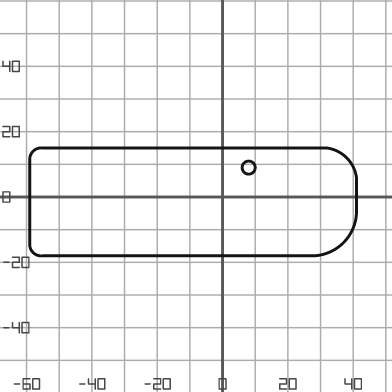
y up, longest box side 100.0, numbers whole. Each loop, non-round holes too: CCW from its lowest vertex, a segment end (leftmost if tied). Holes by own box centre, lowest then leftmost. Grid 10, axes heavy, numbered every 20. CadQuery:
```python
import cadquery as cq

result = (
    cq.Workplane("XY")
    .moveTo(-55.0, -18.0)
    .lineTo(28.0, -18.0)
    .threePointArc((37.0, -14.0), (41.0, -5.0))
    .lineTo(41.0, 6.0)
    .threePointArc((38.0, 12.0), (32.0, 15.0))
    .lineTo(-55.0, 15.0)
    .threePointArc((-58.0, 14.0), (-59.0, 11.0))
    .lineTo(-59.0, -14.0)
    .threePointArc((-58.0, -17.0), (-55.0, -18.0))
    .close()
    .moveTo(8.0, 9.0)
    .circle(2.0)
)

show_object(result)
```